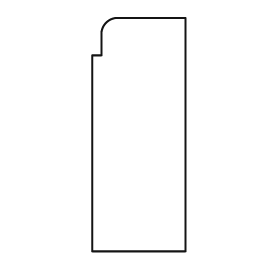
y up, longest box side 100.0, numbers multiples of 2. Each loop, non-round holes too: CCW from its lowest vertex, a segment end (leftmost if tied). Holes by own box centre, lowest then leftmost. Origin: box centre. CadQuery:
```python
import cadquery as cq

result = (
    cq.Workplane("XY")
    .moveTo(-20.0, -50.0)
    .lineTo(20.0, -50.0)
    .lineTo(20.0, 50.0)
    .lineTo(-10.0, 50.0)
    .threePointArc((-14.0, 48.0), (-16.0, 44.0))
    .lineTo(-16.0, 34.0)
    .lineTo(-20.0, 34.0)
    .close()
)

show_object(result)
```